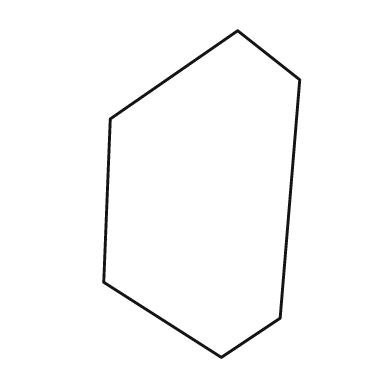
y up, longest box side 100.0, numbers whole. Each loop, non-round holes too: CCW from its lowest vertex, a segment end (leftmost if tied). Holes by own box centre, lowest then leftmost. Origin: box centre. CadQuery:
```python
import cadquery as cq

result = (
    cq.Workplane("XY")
    .moveTo(6.0, -50.0)
    .lineTo(24.0, -38.0)
    .lineTo(30.0, 35.0)
    .lineTo(11.0, 50.0)
    .lineTo(-28.0, 23.0)
    .lineTo(-30.0, -27.0)
    .close()
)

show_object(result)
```